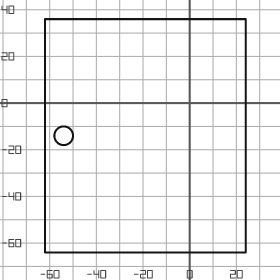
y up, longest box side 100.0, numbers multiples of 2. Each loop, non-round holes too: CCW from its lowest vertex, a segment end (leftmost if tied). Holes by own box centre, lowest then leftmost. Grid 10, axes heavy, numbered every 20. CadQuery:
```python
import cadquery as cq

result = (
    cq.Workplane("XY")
    .moveTo(-62.0, -64.0)
    .lineTo(24.0, -64.0)
    .lineTo(24.0, 36.0)
    .lineTo(-62.0, 36.0)
    .close()
    .moveTo(-54.0, -14.0)
    .circle(4.0)
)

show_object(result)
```